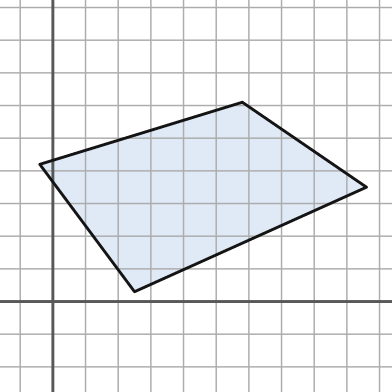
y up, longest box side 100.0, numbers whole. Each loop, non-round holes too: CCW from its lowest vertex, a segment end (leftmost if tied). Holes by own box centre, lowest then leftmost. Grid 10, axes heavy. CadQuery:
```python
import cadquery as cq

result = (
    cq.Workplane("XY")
    .moveTo(25.0, 3.0)
    .lineTo(96.0, 35.0)
    .lineTo(58.0, 61.0)
    .lineTo(-4.0, 42.0)
    .close()
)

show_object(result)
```